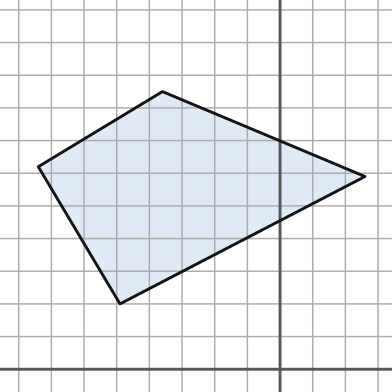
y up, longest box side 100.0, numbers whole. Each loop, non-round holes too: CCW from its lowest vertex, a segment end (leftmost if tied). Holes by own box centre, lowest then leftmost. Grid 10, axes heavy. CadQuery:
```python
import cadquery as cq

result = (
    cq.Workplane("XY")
    .moveTo(-49.0, 20.0)
    .lineTo(26.0, 59.0)
    .lineTo(-36.0, 85.0)
    .lineTo(-74.0, 62.0)
    .close()
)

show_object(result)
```